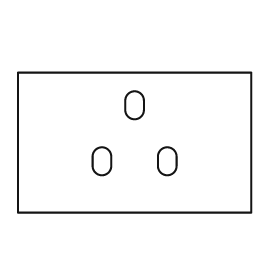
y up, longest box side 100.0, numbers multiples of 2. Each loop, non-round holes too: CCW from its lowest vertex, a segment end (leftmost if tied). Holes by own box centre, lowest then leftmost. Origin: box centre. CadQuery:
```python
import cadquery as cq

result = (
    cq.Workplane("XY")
    .moveTo(-50.0, -30.0)
    .lineTo(50.0, -30.0)
    .lineTo(50.0, 30.0)
    .lineTo(-50.0, 30.0)
    .close()
    .moveTo(-18.0, -10.0)
    .threePointArc((-14.0, -14.0), (-10.0, -10.0))
    .lineTo(-10.0, -6.0)
    .threePointArc((-14.0, -2.0), (-18.0, -6.0))
    .close()
    .moveTo(10.0, -10.0)
    .threePointArc((14.0, -14.0), (18.0, -10.0))
    .lineTo(18.0, -6.0)
    .threePointArc((14.0, -2.0), (10.0, -6.0))
    .close()
    .moveTo(-4.0, 14.0)
    .threePointArc((0.0, 10.0), (4.0, 14.0))
    .lineTo(4.0, 18.0)
    .threePointArc((0.0, 22.0), (-4.0, 18.0))
    .close()
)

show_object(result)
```